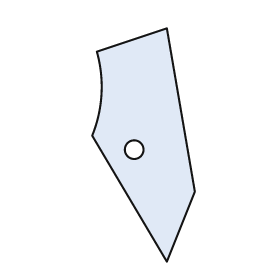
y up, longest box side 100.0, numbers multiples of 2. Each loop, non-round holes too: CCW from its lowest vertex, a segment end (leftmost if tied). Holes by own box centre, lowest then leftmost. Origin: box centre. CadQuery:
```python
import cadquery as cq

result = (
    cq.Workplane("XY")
    .moveTo(10.0, -50.0)
    .lineTo(22.0, -20.0)
    .lineTo(10.0, 50.0)
    .lineTo(-20.0, 40.0)
    .threePointArc((-18.0, 22.0), (-22.0, 4.0))
    .close()
    .moveTo(-4.0, -2.0)
    .circle(4.0)
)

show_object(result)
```